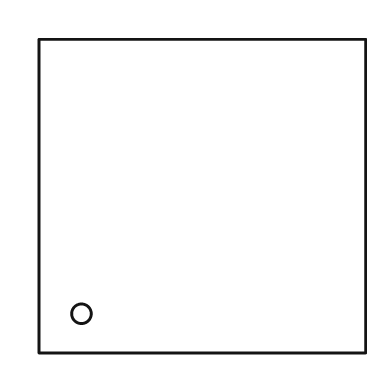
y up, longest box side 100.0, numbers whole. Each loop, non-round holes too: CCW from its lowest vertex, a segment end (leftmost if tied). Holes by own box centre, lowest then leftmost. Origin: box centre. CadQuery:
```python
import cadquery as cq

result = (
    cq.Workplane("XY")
    .moveTo(-50.0, -48.0)
    .lineTo(50.0, -48.0)
    .lineTo(50.0, 48.0)
    .lineTo(-50.0, 48.0)
    .close()
    .moveTo(-37.0, -36.0)
    .circle(3.0)
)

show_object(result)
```